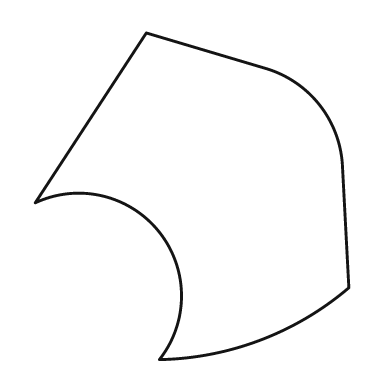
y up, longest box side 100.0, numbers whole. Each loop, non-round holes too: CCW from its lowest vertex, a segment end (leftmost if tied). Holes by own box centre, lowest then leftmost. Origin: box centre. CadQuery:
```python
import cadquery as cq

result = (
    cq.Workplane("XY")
    .moveTo(-10.0, -50.0)
    .threePointArc((21.0, -44.0), (48.0, -28.0))
    .lineTo(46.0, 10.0)
    .threePointArc((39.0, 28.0), (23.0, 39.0))
    .lineTo(-14.0, 50.0)
    .lineTo(-48.0, -2.0)
    .threePointArc((-10.0, -11.0), (-10.0, -50.0))
    .close()
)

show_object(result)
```